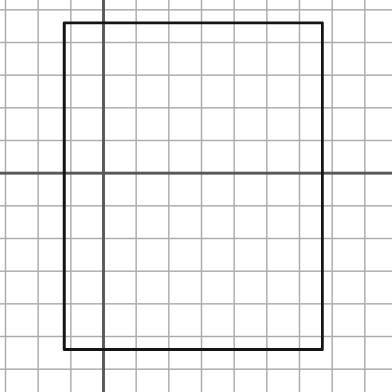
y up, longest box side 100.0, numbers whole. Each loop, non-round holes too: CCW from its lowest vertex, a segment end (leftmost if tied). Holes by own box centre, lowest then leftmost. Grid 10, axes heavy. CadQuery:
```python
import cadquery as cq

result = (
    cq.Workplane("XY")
    .moveTo(-12.0, -54.0)
    .lineTo(67.0, -54.0)
    .lineTo(67.0, 46.0)
    .lineTo(-12.0, 46.0)
    .close()
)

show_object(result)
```